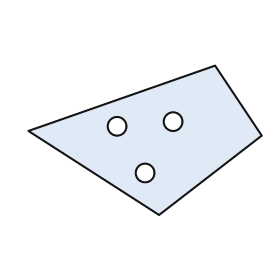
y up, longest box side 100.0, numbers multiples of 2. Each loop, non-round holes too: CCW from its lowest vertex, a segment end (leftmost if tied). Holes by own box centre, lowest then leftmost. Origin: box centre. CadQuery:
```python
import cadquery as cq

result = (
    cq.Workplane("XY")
    .moveTo(6.0, -32.0)
    .lineTo(50.0, 2.0)
    .lineTo(30.0, 32.0)
    .lineTo(-50.0, 4.0)
    .close()
    .moveTo(0.0, -14.0)
    .circle(4.0)
    .moveTo(-12.0, 6.0)
    .circle(4.0)
    .moveTo(12.0, 8.0)
    .circle(4.0)
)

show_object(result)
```